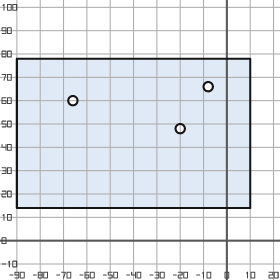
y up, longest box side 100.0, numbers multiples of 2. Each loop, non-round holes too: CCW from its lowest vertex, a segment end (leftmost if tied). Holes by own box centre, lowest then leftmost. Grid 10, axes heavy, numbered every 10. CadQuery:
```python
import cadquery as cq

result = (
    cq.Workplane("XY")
    .moveTo(-90.0, 14.0)
    .lineTo(10.0, 14.0)
    .lineTo(10.0, 78.0)
    .lineTo(-90.0, 78.0)
    .close()
    .moveTo(-20.0, 48.0)
    .circle(2.0)
    .moveTo(-66.0, 60.0)
    .circle(2.0)
    .moveTo(-8.0, 66.0)
    .circle(2.0)
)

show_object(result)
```